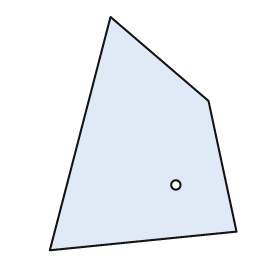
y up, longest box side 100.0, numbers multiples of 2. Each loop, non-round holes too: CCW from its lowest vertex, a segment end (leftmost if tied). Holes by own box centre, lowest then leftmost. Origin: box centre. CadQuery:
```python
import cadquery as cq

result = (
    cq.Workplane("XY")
    .moveTo(-40.0, -50.0)
    .lineTo(40.0, -42.0)
    .lineTo(28.0, 14.0)
    .lineTo(-14.0, 50.0)
    .close()
    .moveTo(14.0, -22.0)
    .circle(2.0)
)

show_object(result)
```